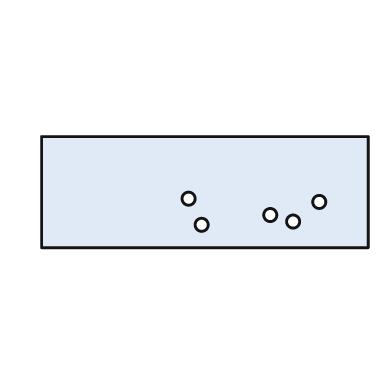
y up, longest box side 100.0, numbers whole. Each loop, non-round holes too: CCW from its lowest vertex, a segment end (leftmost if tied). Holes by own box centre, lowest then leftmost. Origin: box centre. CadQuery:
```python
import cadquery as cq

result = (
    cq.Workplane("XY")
    .moveTo(-50.0, -17.0)
    .lineTo(50.0, -17.0)
    .lineTo(50.0, 17.0)
    .lineTo(-50.0, 17.0)
    .close()
    .moveTo(-1.0, -10.0)
    .circle(2.0)
    .moveTo(27.0, -9.0)
    .circle(2.0)
    .moveTo(20.0, -7.0)
    .circle(2.0)
    .moveTo(35.0, -3.0)
    .circle(2.0)
    .moveTo(-5.0, -2.0)
    .circle(2.0)
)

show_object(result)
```